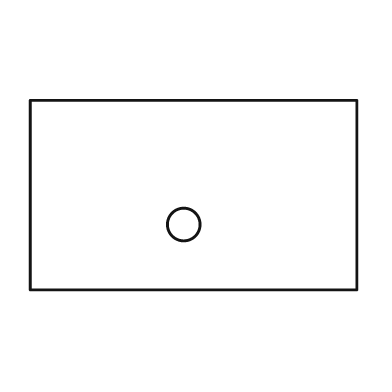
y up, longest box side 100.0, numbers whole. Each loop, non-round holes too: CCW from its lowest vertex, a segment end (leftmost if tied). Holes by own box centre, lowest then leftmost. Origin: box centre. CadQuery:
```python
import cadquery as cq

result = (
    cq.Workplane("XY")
    .moveTo(-50.0, -29.0)
    .lineTo(50.0, -29.0)
    .lineTo(50.0, 29.0)
    .lineTo(-50.0, 29.0)
    .close()
    .moveTo(-3.0, -9.0)
    .circle(5.0)
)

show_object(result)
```